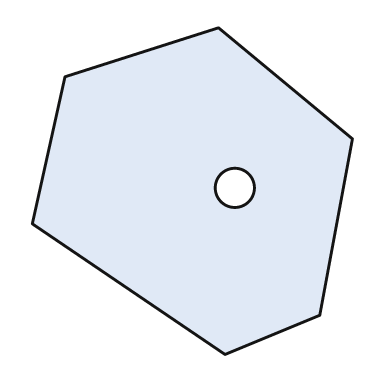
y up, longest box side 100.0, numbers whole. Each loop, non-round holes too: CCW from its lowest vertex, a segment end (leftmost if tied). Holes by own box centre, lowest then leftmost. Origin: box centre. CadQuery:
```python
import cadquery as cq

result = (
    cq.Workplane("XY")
    .moveTo(10.0, -50.0)
    .lineTo(39.0, -38.0)
    .lineTo(49.0, 16.0)
    .lineTo(8.0, 50.0)
    .lineTo(-39.0, 35.0)
    .lineTo(-49.0, -10.0)
    .close()
    .moveTo(13.0, 1.0)
    .circle(6.0)
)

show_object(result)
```